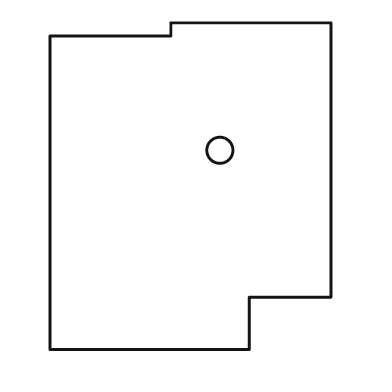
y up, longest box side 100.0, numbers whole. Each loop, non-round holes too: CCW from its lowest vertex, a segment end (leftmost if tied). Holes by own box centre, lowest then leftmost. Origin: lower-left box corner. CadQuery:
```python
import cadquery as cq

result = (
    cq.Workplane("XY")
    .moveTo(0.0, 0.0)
    .lineTo(61.0, 0.0)
    .lineTo(61.0, 16.0)
    .lineTo(86.0, 16.0)
    .lineTo(86.0, 100.0)
    .lineTo(37.0, 100.0)
    .lineTo(37.0, 96.0)
    .lineTo(0.0, 96.0)
    .close()
    .moveTo(52.0, 61.0)
    .circle(4.0)
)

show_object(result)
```